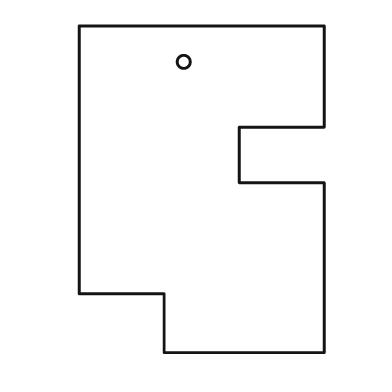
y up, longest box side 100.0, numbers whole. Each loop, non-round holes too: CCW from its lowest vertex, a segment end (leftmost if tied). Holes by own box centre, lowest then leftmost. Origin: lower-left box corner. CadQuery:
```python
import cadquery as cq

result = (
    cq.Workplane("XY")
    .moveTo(26.0, 0.0)
    .lineTo(75.0, 0.0)
    .lineTo(75.0, 52.0)
    .lineTo(49.0, 52.0)
    .lineTo(49.0, 69.0)
    .lineTo(75.0, 69.0)
    .lineTo(75.0, 100.0)
    .lineTo(0.0, 100.0)
    .lineTo(0.0, 18.0)
    .lineTo(26.0, 18.0)
    .close()
    .moveTo(32.0, 89.0)
    .circle(2.0)
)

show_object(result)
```